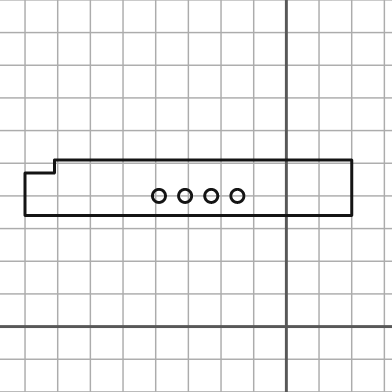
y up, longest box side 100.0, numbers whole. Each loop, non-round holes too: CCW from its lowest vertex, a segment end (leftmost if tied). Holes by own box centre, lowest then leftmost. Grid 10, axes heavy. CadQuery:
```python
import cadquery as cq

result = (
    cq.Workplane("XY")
    .moveTo(-80.0, 34.0)
    .lineTo(20.0, 34.0)
    .lineTo(20.0, 51.0)
    .lineTo(-71.0, 51.0)
    .lineTo(-71.0, 47.0)
    .lineTo(-80.0, 47.0)
    .close()
    .moveTo(-39.0, 40.0)
    .circle(2.0)
    .moveTo(-31.0, 40.0)
    .circle(2.0)
    .moveTo(-23.0, 40.0)
    .circle(2.0)
    .moveTo(-15.0, 40.0)
    .circle(2.0)
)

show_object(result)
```